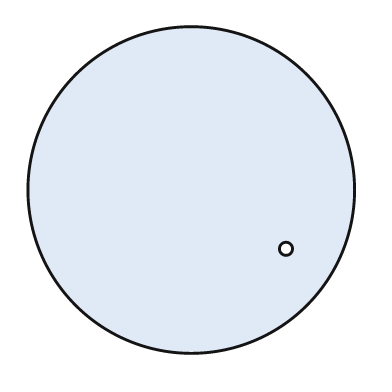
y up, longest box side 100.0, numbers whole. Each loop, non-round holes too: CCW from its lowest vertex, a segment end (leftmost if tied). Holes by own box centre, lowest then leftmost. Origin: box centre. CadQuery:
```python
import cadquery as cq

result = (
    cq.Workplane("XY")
    .moveTo(0.0, 0.0)
    .circle(50.0)
    .moveTo(29.0, -18.0)
    .circle(2.0)
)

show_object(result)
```